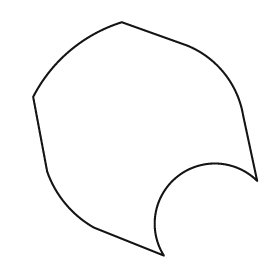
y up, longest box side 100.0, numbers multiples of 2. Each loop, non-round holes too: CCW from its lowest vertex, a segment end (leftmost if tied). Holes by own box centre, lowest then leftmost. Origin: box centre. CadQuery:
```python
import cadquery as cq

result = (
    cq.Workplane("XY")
    .moveTo(8.0, -50.0)
    .threePointArc((14.0, -16.0), (48.0, -18.0))
    .lineTo(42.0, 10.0)
    .threePointArc((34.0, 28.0), (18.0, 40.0))
    .lineTo(-10.0, 50.0)
    .threePointArc((-32.0, 38.0), (-48.0, 18.0))
    .lineTo(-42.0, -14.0)
    .threePointArc((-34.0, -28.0), (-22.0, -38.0))
    .close()
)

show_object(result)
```